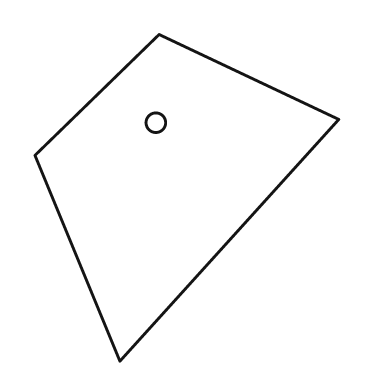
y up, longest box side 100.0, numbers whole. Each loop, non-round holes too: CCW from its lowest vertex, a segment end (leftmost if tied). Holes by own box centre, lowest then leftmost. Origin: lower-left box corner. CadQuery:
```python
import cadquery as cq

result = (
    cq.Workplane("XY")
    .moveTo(26.0, 0.0)
    .lineTo(93.0, 74.0)
    .lineTo(38.0, 100.0)
    .lineTo(0.0, 63.0)
    .close()
    .moveTo(37.0, 73.0)
    .circle(3.0)
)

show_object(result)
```